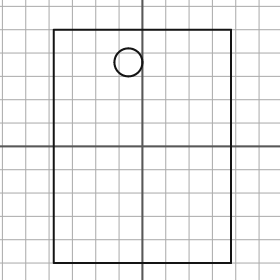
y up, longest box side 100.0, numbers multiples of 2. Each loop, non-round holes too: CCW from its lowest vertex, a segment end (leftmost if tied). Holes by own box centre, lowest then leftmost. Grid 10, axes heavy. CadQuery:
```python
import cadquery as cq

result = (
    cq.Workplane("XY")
    .moveTo(-38.0, -50.0)
    .lineTo(38.0, -50.0)
    .lineTo(38.0, 50.0)
    .lineTo(-38.0, 50.0)
    .close()
    .moveTo(-6.0, 36.0)
    .circle(6.0)
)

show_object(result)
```